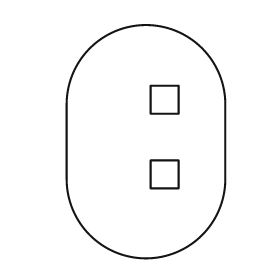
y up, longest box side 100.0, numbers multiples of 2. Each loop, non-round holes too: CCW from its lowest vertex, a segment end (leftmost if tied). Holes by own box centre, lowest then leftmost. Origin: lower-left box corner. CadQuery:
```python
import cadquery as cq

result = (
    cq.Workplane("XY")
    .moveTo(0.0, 34.0)
    .threePointArc((34.0, 0.0), (68.0, 34.0))
    .lineTo(68.0, 66.0)
    .threePointArc((34.0, 100.0), (0.0, 66.0))
    .close()
    .moveTo(36.0, 30.0)
    .lineTo(48.0, 30.0)
    .lineTo(48.0, 42.0)
    .lineTo(36.0, 42.0)
    .close()
    .moveTo(36.0, 62.0)
    .lineTo(48.0, 62.0)
    .lineTo(48.0, 74.0)
    .lineTo(36.0, 74.0)
    .close()
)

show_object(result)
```